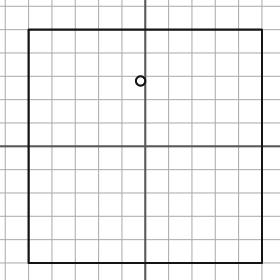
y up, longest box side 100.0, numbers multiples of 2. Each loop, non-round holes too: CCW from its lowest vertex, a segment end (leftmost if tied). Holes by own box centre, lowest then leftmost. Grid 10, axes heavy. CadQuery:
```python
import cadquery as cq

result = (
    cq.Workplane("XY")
    .moveTo(-50.0, -50.0)
    .lineTo(50.0, -50.0)
    .lineTo(50.0, 50.0)
    .lineTo(-50.0, 50.0)
    .close()
    .moveTo(-2.0, 28.0)
    .circle(2.0)
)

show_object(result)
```